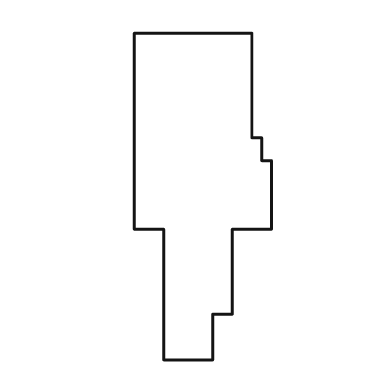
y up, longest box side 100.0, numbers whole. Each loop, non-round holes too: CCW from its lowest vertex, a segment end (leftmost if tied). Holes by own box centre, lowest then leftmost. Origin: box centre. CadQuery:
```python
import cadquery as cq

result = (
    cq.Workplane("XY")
    .moveTo(-12.0, -50.0)
    .lineTo(3.0, -50.0)
    .lineTo(3.0, -36.0)
    .lineTo(9.0, -36.0)
    .lineTo(9.0, -10.0)
    .lineTo(21.0, -10.0)
    .lineTo(21.0, 11.0)
    .lineTo(18.0, 11.0)
    .lineTo(18.0, 18.0)
    .lineTo(15.0, 18.0)
    .lineTo(15.0, 50.0)
    .lineTo(-21.0, 50.0)
    .lineTo(-21.0, -10.0)
    .lineTo(-12.0, -10.0)
    .close()
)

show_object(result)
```